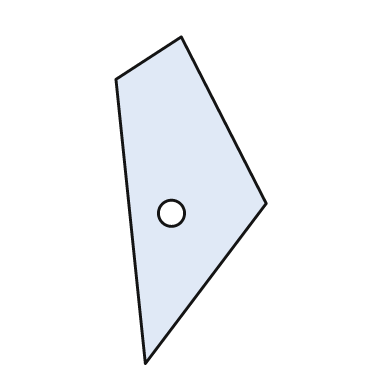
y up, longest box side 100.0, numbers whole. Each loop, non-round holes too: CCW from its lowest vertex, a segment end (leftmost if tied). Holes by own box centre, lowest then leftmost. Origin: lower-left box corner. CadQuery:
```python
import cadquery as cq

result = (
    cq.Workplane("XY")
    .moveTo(9.0, 0.0)
    .lineTo(46.0, 49.0)
    .lineTo(20.0, 100.0)
    .lineTo(0.0, 87.0)
    .close()
    .moveTo(17.0, 46.0)
    .circle(4.0)
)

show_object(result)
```